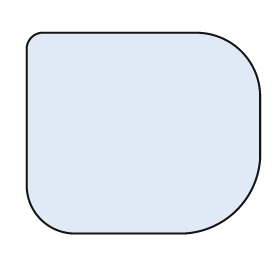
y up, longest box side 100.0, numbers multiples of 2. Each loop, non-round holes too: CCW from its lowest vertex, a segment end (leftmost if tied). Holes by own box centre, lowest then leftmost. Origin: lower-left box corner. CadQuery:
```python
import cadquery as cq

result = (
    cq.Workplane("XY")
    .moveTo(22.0, 0.0)
    .lineTo(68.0, 0.0)
    .threePointArc((90.0, 10.0), (100.0, 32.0))
    .lineTo(100.0, 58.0)
    .threePointArc((92.0, 78.0), (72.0, 86.0))
    .lineTo(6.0, 86.0)
    .threePointArc((2.0, 84.0), (0.0, 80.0))
    .lineTo(0.0, 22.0)
    .threePointArc((6.0, 6.0), (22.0, 0.0))
    .close()
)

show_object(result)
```